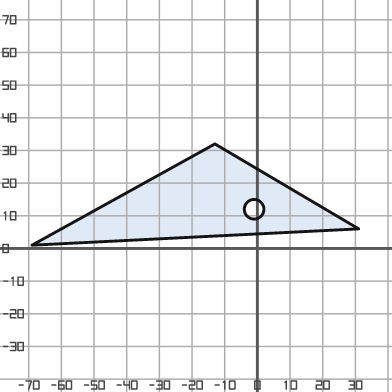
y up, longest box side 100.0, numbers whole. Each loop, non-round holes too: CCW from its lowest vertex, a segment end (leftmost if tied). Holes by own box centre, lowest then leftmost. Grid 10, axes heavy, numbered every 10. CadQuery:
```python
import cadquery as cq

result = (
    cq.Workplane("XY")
    .moveTo(-69.0, 1.0)
    .lineTo(31.0, 6.0)
    .lineTo(-13.0, 32.0)
    .close()
    .moveTo(-1.0, 12.0)
    .circle(3.0)
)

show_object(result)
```